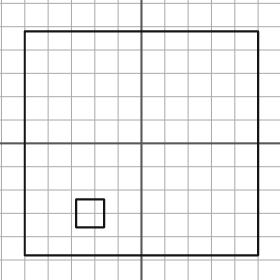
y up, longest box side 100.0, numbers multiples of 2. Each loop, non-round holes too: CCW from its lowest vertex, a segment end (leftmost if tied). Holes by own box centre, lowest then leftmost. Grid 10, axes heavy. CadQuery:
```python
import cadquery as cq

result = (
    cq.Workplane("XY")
    .moveTo(-50.0, -48.0)
    .lineTo(50.0, -48.0)
    .lineTo(50.0, 48.0)
    .lineTo(-50.0, 48.0)
    .close()
    .moveTo(-28.0, -36.0)
    .lineTo(-16.0, -36.0)
    .lineTo(-16.0, -24.0)
    .lineTo(-28.0, -24.0)
    .close()
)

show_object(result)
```